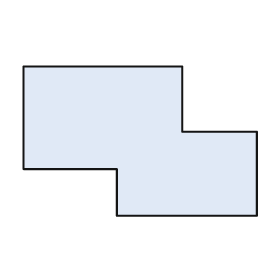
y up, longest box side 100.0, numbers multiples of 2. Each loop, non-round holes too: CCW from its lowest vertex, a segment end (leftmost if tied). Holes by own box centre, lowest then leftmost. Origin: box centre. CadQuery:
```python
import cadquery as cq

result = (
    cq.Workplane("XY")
    .moveTo(-10.0, -32.0)
    .lineTo(50.0, -32.0)
    .lineTo(50.0, 4.0)
    .lineTo(18.0, 4.0)
    .lineTo(18.0, 32.0)
    .lineTo(-50.0, 32.0)
    .lineTo(-50.0, -12.0)
    .lineTo(-10.0, -12.0)
    .close()
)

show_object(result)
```